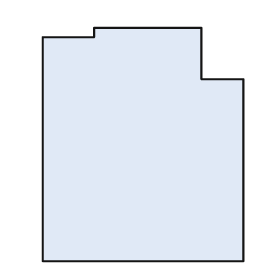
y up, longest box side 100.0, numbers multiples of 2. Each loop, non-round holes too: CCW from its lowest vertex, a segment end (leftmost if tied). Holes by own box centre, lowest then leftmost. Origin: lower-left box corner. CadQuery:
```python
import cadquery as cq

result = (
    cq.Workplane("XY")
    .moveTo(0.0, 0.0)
    .lineTo(86.0, 0.0)
    .lineTo(86.0, 78.0)
    .lineTo(68.0, 78.0)
    .lineTo(68.0, 100.0)
    .lineTo(22.0, 100.0)
    .lineTo(22.0, 96.0)
    .lineTo(0.0, 96.0)
    .close()
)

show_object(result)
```